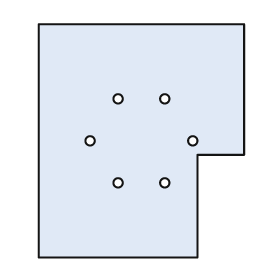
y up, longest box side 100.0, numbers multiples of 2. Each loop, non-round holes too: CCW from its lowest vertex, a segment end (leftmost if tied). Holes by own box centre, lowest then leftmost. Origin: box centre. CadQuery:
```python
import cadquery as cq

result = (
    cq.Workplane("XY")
    .moveTo(-44.0, -50.0)
    .lineTo(24.0, -50.0)
    .lineTo(24.0, -6.0)
    .lineTo(44.0, -6.0)
    .lineTo(44.0, 50.0)
    .lineTo(-44.0, 50.0)
    .close()
    .moveTo(-10.0, -18.0)
    .circle(2.0)
    .moveTo(10.0, -18.0)
    .circle(2.0)
    .moveTo(-22.0, 0.0)
    .circle(2.0)
    .moveTo(22.0, 0.0)
    .circle(2.0)
    .moveTo(-10.0, 18.0)
    .circle(2.0)
    .moveTo(10.0, 18.0)
    .circle(2.0)
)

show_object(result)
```